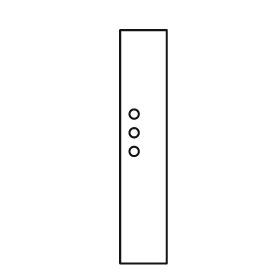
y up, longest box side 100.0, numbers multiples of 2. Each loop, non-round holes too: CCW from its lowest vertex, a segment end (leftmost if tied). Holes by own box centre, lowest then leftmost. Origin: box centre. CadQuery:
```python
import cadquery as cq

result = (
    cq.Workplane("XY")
    .moveTo(-10.0, -50.0)
    .lineTo(10.0, -50.0)
    .lineTo(10.0, 50.0)
    .lineTo(-10.0, 50.0)
    .close()
    .moveTo(-4.0, -2.0)
    .circle(2.0)
    .moveTo(-4.0, 6.0)
    .circle(2.0)
    .moveTo(-4.0, 14.0)
    .circle(2.0)
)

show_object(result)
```